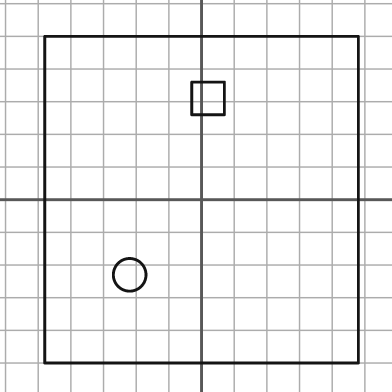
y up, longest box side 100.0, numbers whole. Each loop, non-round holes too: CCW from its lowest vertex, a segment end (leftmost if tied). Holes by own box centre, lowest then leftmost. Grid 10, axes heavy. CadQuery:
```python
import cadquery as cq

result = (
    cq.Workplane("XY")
    .moveTo(-48.0, -50.0)
    .lineTo(48.0, -50.0)
    .lineTo(48.0, 50.0)
    .lineTo(-48.0, 50.0)
    .close()
    .moveTo(-22.0, -23.0)
    .circle(5.0)
    .moveTo(-3.0, 26.0)
    .lineTo(7.0, 26.0)
    .lineTo(7.0, 36.0)
    .lineTo(-3.0, 36.0)
    .close()
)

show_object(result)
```